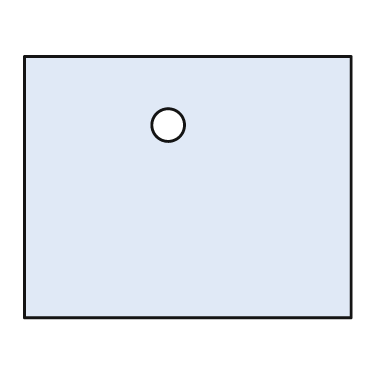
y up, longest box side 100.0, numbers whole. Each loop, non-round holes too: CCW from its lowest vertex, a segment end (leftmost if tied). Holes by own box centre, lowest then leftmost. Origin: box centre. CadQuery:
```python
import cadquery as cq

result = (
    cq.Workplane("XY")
    .moveTo(-50.0, -40.0)
    .lineTo(50.0, -40.0)
    .lineTo(50.0, 40.0)
    .lineTo(-50.0, 40.0)
    .close()
    .moveTo(-6.0, 19.0)
    .circle(5.0)
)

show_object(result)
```